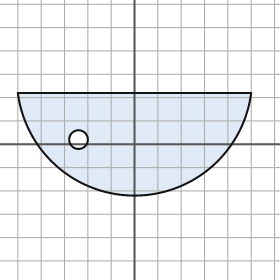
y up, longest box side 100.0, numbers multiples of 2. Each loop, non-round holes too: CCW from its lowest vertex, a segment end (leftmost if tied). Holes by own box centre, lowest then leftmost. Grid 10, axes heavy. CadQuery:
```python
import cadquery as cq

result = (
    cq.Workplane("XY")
    .moveTo(-50.0, 22.0)
    .threePointArc((0.0, -22.0), (50.0, 22.0))
    .close()
    .moveTo(-24.0, 2.0)
    .circle(4.0)
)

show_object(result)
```